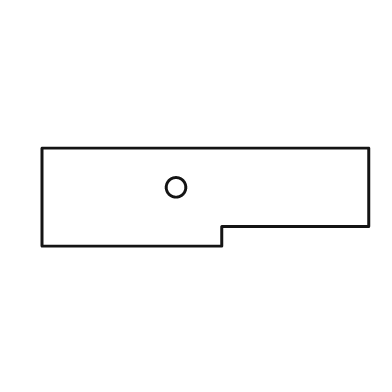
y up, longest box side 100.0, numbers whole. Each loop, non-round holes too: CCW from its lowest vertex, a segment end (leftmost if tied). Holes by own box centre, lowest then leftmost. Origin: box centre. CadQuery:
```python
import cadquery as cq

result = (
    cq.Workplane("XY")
    .moveTo(-50.0, -15.0)
    .lineTo(5.0, -15.0)
    .lineTo(5.0, -9.0)
    .lineTo(50.0, -9.0)
    .lineTo(50.0, 15.0)
    .lineTo(-50.0, 15.0)
    .close()
    .moveTo(-9.0, 3.0)
    .circle(3.0)
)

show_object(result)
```